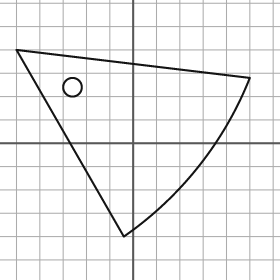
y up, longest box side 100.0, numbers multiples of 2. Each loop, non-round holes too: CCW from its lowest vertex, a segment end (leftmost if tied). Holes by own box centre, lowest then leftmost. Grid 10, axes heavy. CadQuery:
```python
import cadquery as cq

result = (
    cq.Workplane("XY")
    .moveTo(-4.0, -40.0)
    .threePointArc((28.0, -10.0), (50.0, 28.0))
    .lineTo(-50.0, 40.0)
    .close()
    .moveTo(-26.0, 24.0)
    .circle(4.0)
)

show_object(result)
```